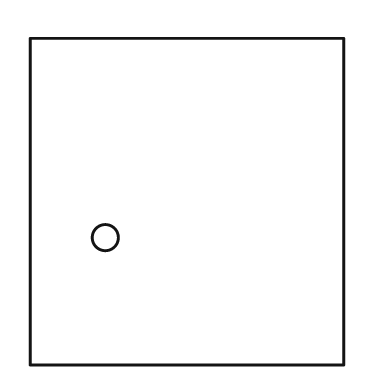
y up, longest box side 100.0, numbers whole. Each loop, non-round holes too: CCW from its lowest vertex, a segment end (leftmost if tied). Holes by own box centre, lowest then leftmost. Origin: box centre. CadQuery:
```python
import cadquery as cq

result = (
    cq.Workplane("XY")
    .moveTo(-48.0, -50.0)
    .lineTo(48.0, -50.0)
    .lineTo(48.0, 50.0)
    .lineTo(-48.0, 50.0)
    .close()
    .moveTo(-25.0, -11.0)
    .circle(4.0)
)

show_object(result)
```